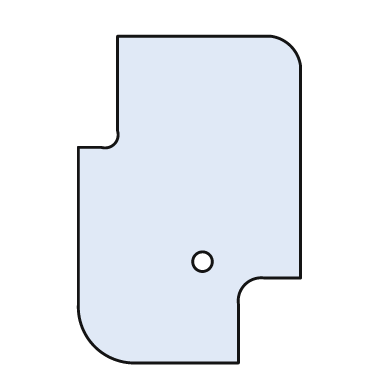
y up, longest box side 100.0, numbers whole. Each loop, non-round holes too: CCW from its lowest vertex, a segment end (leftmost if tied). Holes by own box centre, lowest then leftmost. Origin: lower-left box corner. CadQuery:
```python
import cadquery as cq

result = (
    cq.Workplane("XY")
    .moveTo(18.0, 0.0)
    .lineTo(49.0, 0.0)
    .lineTo(49.0, 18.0)
    .threePointArc((51.0, 24.0), (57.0, 26.0))
    .lineTo(68.0, 26.0)
    .lineTo(68.0, 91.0)
    .threePointArc((65.0, 97.0), (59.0, 100.0))
    .lineTo(12.0, 100.0)
    .lineTo(12.0, 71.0)
    .threePointArc((11.0, 67.0), (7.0, 66.0))
    .lineTo(0.0, 66.0)
    .lineTo(0.0, 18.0)
    .threePointArc((5.0, 5.0), (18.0, 0.0))
    .close()
    .moveTo(38.0, 31.0)
    .circle(3.0)
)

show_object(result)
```